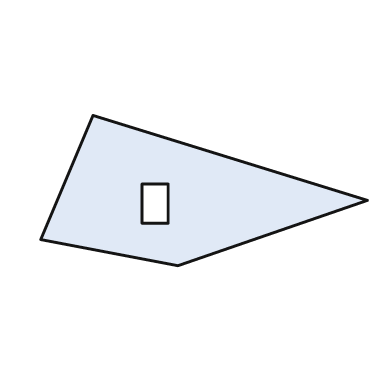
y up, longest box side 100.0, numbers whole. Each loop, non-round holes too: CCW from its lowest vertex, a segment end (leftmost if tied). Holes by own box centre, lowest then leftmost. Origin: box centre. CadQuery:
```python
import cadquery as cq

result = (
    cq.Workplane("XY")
    .moveTo(-8.0, -23.0)
    .lineTo(50.0, -3.0)
    .lineTo(-34.0, 23.0)
    .lineTo(-50.0, -15.0)
    .close()
    .moveTo(-19.0, -10.0)
    .lineTo(-11.0, -10.0)
    .lineTo(-11.0, 2.0)
    .lineTo(-19.0, 2.0)
    .close()
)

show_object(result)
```